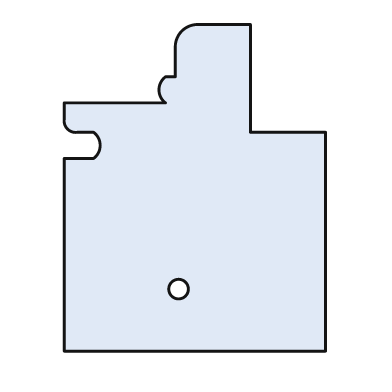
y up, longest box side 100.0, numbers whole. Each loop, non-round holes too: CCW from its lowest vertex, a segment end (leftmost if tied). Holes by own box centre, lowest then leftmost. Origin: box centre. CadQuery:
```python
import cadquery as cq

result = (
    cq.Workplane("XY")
    .moveTo(-40.0, -50.0)
    .lineTo(40.0, -50.0)
    .lineTo(40.0, 17.0)
    .lineTo(17.0, 17.0)
    .lineTo(17.0, 50.0)
    .lineTo(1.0, 50.0)
    .threePointArc((-4.0, 48.0), (-6.0, 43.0))
    .lineTo(-6.0, 34.0)
    .lineTo(-9.0, 34.0)
    .threePointArc((-11.0, 30.0), (-9.0, 26.0))
    .lineTo(-40.0, 26.0)
    .lineTo(-40.0, 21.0)
    .threePointArc((-39.0, 18.0), (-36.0, 17.0))
    .lineTo(-31.0, 17.0)
    .threePointArc((-29.0, 13.0), (-31.0, 9.0))
    .lineTo(-40.0, 9.0)
    .close()
    .moveTo(-5.0, -31.0)
    .circle(3.0)
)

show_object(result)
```